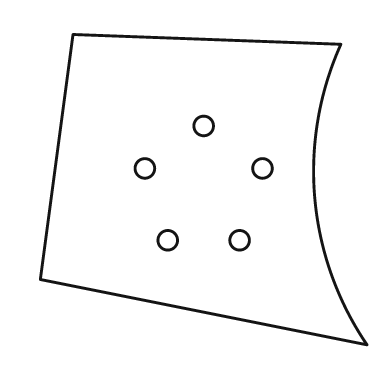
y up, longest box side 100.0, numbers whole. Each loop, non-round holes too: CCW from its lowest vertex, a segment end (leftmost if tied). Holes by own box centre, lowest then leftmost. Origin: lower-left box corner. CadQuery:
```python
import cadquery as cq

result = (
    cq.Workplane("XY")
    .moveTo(100.0, 0.0)
    .threePointArc((84.0, 45.0), (92.0, 92.0))
    .lineTo(10.0, 95.0)
    .lineTo(0.0, 20.0)
    .close()
    .moveTo(39.0, 32.0)
    .circle(3.0)
    .moveTo(61.0, 32.0)
    .circle(3.0)
    .moveTo(32.0, 54.0)
    .circle(3.0)
    .moveTo(68.0, 54.0)
    .circle(3.0)
    .moveTo(50.0, 67.0)
    .circle(3.0)
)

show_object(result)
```